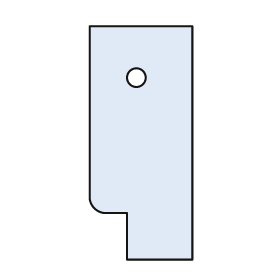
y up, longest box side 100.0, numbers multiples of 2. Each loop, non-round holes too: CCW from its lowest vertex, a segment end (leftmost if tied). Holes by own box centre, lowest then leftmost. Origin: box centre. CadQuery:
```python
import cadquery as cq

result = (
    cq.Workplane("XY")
    .moveTo(-6.0, -50.0)
    .lineTo(22.0, -50.0)
    .lineTo(22.0, 50.0)
    .lineTo(-22.0, 50.0)
    .lineTo(-22.0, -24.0)
    .threePointArc((-20.0, -28.0), (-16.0, -30.0))
    .lineTo(-6.0, -30.0)
    .close()
    .moveTo(-2.0, 28.0)
    .circle(4.0)
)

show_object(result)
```